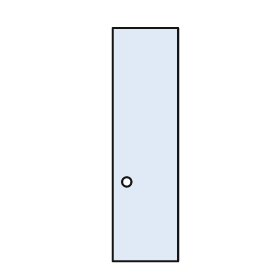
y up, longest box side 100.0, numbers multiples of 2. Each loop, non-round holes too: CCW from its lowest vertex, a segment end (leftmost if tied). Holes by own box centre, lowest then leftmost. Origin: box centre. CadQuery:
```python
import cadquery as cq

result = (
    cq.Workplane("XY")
    .moveTo(-14.0, -50.0)
    .lineTo(14.0, -50.0)
    .lineTo(14.0, 50.0)
    .lineTo(-14.0, 50.0)
    .close()
    .moveTo(-8.0, -16.0)
    .circle(2.0)
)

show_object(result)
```